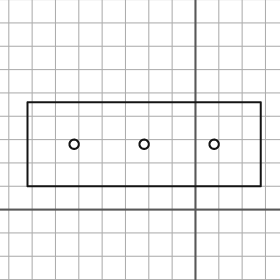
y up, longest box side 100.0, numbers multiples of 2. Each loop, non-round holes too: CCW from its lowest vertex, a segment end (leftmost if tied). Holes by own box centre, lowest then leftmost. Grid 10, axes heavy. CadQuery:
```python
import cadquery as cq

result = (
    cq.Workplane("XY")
    .moveTo(-72.0, 10.0)
    .lineTo(28.0, 10.0)
    .lineTo(28.0, 46.0)
    .lineTo(-72.0, 46.0)
    .close()
    .moveTo(-52.0, 28.0)
    .circle(2.0)
    .moveTo(-22.0, 28.0)
    .circle(2.0)
    .moveTo(8.0, 28.0)
    .circle(2.0)
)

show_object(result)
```